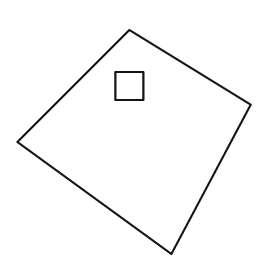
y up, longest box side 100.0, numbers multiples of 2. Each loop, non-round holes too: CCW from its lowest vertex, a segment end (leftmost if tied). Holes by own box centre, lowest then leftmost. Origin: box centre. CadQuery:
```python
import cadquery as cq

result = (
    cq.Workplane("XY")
    .moveTo(16.0, -48.0)
    .lineTo(50.0, 16.0)
    .lineTo(-2.0, 48.0)
    .lineTo(-50.0, 0.0)
    .close()
    .moveTo(-8.0, 18.0)
    .lineTo(4.0, 18.0)
    .lineTo(4.0, 30.0)
    .lineTo(-8.0, 30.0)
    .close()
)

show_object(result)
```